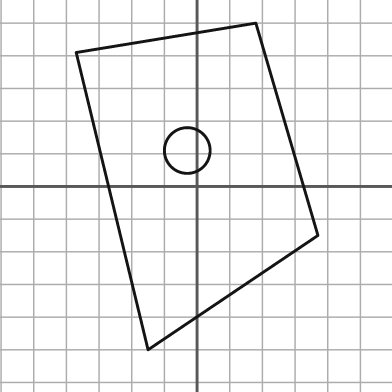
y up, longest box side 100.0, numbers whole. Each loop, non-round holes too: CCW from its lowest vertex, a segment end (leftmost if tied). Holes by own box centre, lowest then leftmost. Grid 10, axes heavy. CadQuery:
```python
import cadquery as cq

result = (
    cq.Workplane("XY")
    .moveTo(-15.0, -50.0)
    .lineTo(37.0, -15.0)
    .lineTo(18.0, 50.0)
    .lineTo(-37.0, 41.0)
    .close()
    .moveTo(-3.0, 11.0)
    .circle(7.0)
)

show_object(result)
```